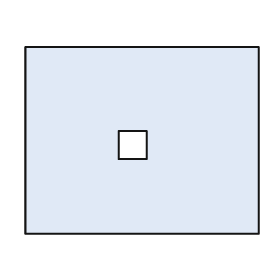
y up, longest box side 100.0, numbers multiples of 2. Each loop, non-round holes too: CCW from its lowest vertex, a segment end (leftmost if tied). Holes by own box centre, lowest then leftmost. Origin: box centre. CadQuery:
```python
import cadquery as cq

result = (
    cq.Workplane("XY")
    .moveTo(-50.0, -40.0)
    .lineTo(50.0, -40.0)
    .lineTo(50.0, 40.0)
    .lineTo(-50.0, 40.0)
    .close()
    .moveTo(-10.0, -8.0)
    .lineTo(2.0, -8.0)
    .lineTo(2.0, 4.0)
    .lineTo(-10.0, 4.0)
    .close()
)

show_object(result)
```